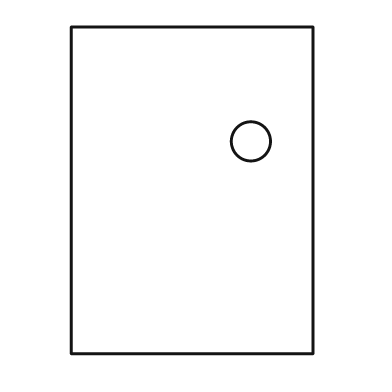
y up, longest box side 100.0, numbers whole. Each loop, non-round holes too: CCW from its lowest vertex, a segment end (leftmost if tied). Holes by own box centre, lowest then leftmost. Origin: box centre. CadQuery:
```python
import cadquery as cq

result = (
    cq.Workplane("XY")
    .moveTo(-37.0, -50.0)
    .lineTo(37.0, -50.0)
    .lineTo(37.0, 50.0)
    .lineTo(-37.0, 50.0)
    .close()
    .moveTo(18.0, 15.0)
    .circle(6.0)
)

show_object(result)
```